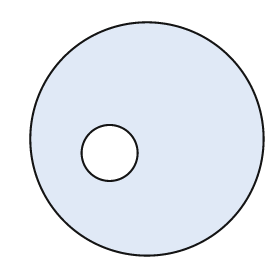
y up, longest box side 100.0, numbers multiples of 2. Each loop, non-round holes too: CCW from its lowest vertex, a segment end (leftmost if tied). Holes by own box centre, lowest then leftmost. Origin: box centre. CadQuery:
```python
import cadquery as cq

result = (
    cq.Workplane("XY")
    .moveTo(0.0, 0.0)
    .circle(50.0)
    .moveTo(-16.0, -6.0)
    .circle(12.0)
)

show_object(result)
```